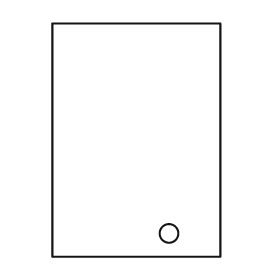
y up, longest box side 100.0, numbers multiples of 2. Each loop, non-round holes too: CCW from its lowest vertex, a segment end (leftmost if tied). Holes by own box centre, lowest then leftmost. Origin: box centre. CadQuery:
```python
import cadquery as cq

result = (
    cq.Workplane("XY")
    .moveTo(-36.0, -50.0)
    .lineTo(36.0, -50.0)
    .lineTo(36.0, 50.0)
    .lineTo(-36.0, 50.0)
    .close()
    .moveTo(14.0, -40.0)
    .circle(4.0)
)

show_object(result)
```